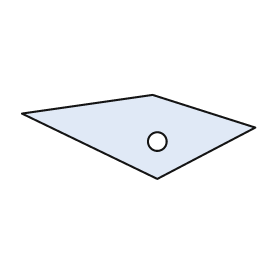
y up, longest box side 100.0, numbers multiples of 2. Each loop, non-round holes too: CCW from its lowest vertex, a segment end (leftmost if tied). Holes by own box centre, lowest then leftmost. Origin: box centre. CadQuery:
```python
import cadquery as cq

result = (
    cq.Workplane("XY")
    .moveTo(8.0, -18.0)
    .lineTo(50.0, 4.0)
    .lineTo(6.0, 18.0)
    .lineTo(-50.0, 10.0)
    .close()
    .moveTo(8.0, -2.0)
    .circle(4.0)
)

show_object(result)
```